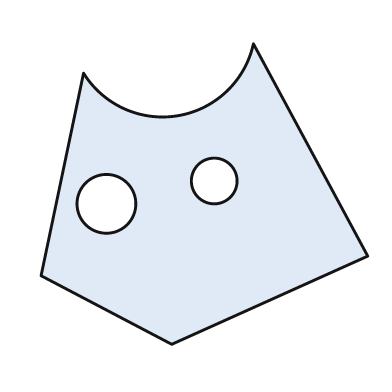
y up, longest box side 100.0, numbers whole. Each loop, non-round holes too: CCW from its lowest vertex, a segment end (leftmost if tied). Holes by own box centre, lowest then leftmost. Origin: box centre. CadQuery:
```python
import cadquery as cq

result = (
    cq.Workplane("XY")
    .moveTo(-10.0, -46.0)
    .lineTo(50.0, -19.0)
    .lineTo(15.0, 46.0)
    .threePointArc((-8.0, 24.0), (-37.0, 37.0))
    .lineTo(-50.0, -25.0)
    .close()
    .moveTo(-30.0, -3.0)
    .circle(9.0)
    .moveTo(3.0, 4.0)
    .circle(7.0)
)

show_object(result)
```